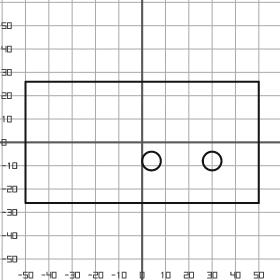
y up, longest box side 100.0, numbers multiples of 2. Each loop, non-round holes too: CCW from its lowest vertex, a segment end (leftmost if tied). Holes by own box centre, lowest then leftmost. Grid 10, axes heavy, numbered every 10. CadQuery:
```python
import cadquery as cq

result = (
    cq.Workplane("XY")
    .moveTo(-50.0, -26.0)
    .lineTo(50.0, -26.0)
    .lineTo(50.0, 26.0)
    .lineTo(-50.0, 26.0)
    .close()
    .moveTo(4.0, -8.0)
    .circle(4.0)
    .moveTo(30.0, -8.0)
    .circle(4.0)
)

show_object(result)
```